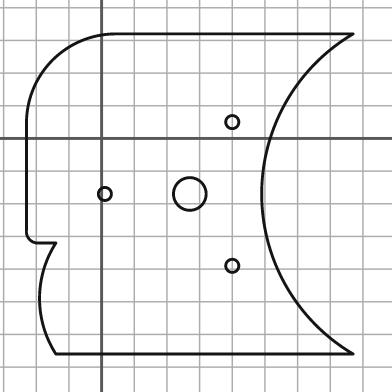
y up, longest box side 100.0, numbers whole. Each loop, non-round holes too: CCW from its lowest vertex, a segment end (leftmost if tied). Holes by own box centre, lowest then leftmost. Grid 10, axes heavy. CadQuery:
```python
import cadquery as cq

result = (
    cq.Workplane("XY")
    .moveTo(-14.0, -66.0)
    .lineTo(77.0, -66.0)
    .threePointArc((49.0, -17.0), (77.0, 32.0))
    .lineTo(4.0, 32.0)
    .threePointArc((-15.0, 24.0), (-23.0, 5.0))
    .lineTo(-23.0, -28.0)
    .threePointArc((-22.0, -31.0), (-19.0, -32.0))
    .lineTo(-14.0, -32.0)
    .threePointArc((-19.0, -49.0), (-14.0, -66.0))
    .close()
    .moveTo(40.0, -39.0)
    .circle(2.0)
    .moveTo(1.0, -17.0)
    .circle(2.0)
    .moveTo(27.0, -17.0)
    .circle(5.0)
    .moveTo(40.0, 5.0)
    .circle(2.0)
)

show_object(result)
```